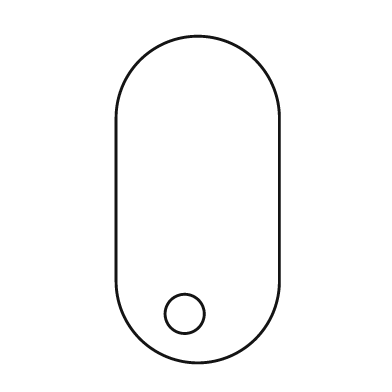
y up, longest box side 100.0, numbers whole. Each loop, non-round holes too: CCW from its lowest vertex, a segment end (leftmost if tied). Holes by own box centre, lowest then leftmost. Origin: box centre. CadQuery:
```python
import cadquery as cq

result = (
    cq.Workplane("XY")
    .moveTo(-25.0, -25.0)
    .threePointArc((0.0, -50.0), (25.0, -25.0))
    .lineTo(25.0, 25.0)
    .threePointArc((0.0, 50.0), (-25.0, 25.0))
    .close()
    .moveTo(-4.0, -35.0)
    .circle(6.0)
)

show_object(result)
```